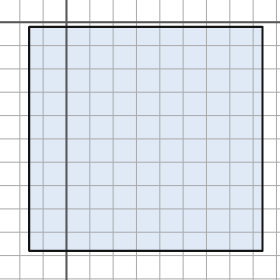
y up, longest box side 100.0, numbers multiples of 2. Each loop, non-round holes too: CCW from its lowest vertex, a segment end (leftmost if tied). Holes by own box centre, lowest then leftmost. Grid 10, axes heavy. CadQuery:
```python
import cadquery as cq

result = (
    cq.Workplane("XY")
    .moveTo(-16.0, -98.0)
    .lineTo(84.0, -98.0)
    .lineTo(84.0, -2.0)
    .lineTo(-16.0, -2.0)
    .close()
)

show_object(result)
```